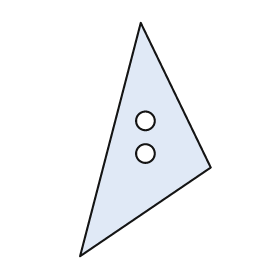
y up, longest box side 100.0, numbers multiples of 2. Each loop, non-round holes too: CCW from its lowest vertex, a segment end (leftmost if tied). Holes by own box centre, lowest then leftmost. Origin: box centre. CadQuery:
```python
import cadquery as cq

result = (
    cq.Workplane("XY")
    .moveTo(-28.0, -50.0)
    .lineTo(28.0, -12.0)
    .lineTo(-2.0, 50.0)
    .close()
    .moveTo(0.0, -6.0)
    .circle(4.0)
    .moveTo(0.0, 8.0)
    .circle(4.0)
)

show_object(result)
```